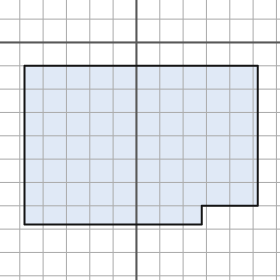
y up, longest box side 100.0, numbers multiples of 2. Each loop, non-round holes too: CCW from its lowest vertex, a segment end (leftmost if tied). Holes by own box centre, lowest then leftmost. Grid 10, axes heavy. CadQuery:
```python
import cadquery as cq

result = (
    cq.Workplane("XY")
    .moveTo(-48.0, -78.0)
    .lineTo(28.0, -78.0)
    .lineTo(28.0, -70.0)
    .lineTo(52.0, -70.0)
    .lineTo(52.0, -10.0)
    .lineTo(-48.0, -10.0)
    .close()
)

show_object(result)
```